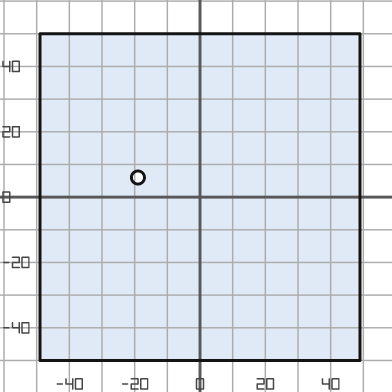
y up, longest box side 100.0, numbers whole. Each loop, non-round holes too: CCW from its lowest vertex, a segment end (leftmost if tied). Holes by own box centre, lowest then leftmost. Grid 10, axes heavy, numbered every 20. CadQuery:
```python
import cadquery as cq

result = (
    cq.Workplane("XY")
    .moveTo(-49.0, -50.0)
    .lineTo(49.0, -50.0)
    .lineTo(49.0, 50.0)
    .lineTo(-49.0, 50.0)
    .close()
    .moveTo(-19.0, 6.0)
    .circle(2.0)
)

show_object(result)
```